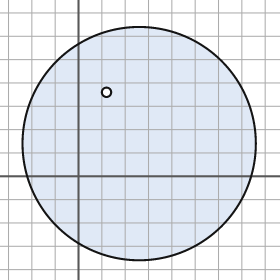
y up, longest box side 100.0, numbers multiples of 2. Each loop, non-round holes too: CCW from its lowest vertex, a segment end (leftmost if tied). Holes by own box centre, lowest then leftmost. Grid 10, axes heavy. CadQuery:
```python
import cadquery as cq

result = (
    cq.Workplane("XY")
    .moveTo(26.0, 14.0)
    .circle(50.0)
    .moveTo(12.0, 36.0)
    .circle(2.0)
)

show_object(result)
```